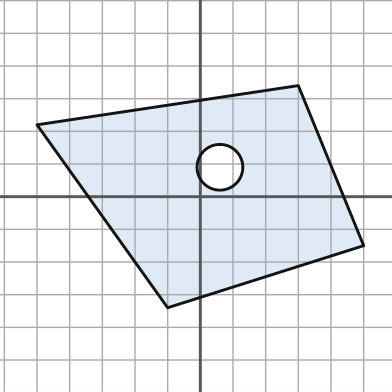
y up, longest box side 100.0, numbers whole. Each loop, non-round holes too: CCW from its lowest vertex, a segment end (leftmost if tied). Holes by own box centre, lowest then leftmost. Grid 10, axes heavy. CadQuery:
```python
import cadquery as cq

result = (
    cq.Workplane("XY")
    .moveTo(-10.0, -34.0)
    .lineTo(50.0, -15.0)
    .lineTo(30.0, 34.0)
    .lineTo(-50.0, 22.0)
    .close()
    .moveTo(6.0, 9.0)
    .circle(7.0)
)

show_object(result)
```